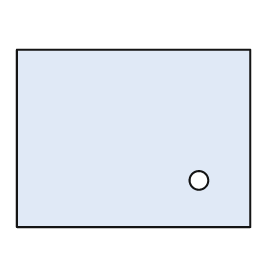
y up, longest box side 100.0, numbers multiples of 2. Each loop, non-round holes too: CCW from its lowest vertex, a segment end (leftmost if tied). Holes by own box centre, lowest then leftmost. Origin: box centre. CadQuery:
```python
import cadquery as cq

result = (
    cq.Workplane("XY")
    .moveTo(-50.0, -38.0)
    .lineTo(50.0, -38.0)
    .lineTo(50.0, 38.0)
    .lineTo(-50.0, 38.0)
    .close()
    .moveTo(28.0, -18.0)
    .circle(4.0)
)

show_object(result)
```